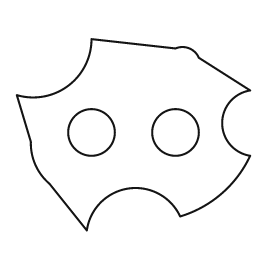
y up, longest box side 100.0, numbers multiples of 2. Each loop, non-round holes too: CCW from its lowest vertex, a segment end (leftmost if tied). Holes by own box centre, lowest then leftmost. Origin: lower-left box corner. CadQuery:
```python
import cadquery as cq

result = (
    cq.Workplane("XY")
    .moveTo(30.0, 0.0)
    .threePointArc((48.0, 18.0), (70.0, 6.0))
    .threePointArc((88.0, 16.0), (100.0, 32.0))
    .threePointArc((88.0, 46.0), (100.0, 60.0))
    .lineTo(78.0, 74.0)
    .threePointArc((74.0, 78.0), (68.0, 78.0))
    .lineTo(32.0, 82.0)
    .threePointArc((22.0, 62.0), (0.0, 58.0))
    .lineTo(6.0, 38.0)
    .threePointArc((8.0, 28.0), (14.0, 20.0))
    .close()
    .moveTo(32.0, 42.0)
    .circle(10.0)
    .moveTo(68.0, 42.0)
    .circle(10.0)
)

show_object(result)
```